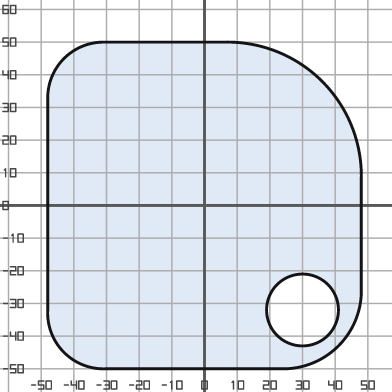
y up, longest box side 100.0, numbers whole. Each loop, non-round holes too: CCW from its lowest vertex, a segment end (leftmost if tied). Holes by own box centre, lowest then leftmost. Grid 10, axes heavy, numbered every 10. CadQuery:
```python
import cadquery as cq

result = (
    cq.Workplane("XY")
    .moveTo(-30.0, -50.0)
    .lineTo(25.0, -50.0)
    .threePointArc((41.0, -43.0), (48.0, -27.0))
    .lineTo(48.0, 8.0)
    .threePointArc((36.0, 38.0), (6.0, 50.0))
    .lineTo(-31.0, 50.0)
    .threePointArc((-43.0, 45.0), (-48.0, 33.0))
    .lineTo(-48.0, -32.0)
    .threePointArc((-43.0, -45.0), (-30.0, -50.0))
    .close()
    .moveTo(30.0, -32.0)
    .circle(11.0)
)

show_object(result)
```